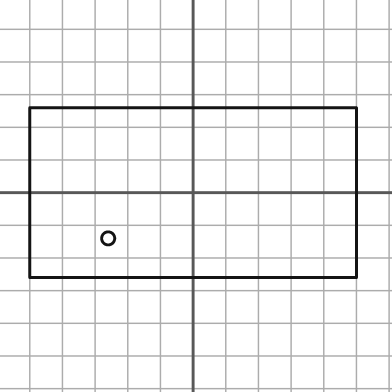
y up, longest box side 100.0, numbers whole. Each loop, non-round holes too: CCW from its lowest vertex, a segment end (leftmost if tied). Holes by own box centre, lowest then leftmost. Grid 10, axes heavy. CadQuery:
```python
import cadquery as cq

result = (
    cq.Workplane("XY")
    .moveTo(-50.0, -26.0)
    .lineTo(50.0, -26.0)
    .lineTo(50.0, 26.0)
    .lineTo(-50.0, 26.0)
    .close()
    .moveTo(-26.0, -14.0)
    .circle(2.0)
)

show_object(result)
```